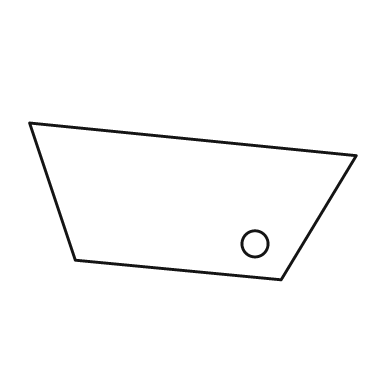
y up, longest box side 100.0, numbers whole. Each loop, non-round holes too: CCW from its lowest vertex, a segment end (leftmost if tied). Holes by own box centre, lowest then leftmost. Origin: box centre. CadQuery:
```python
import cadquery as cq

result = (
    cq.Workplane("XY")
    .moveTo(27.0, -24.0)
    .lineTo(50.0, 14.0)
    .lineTo(-50.0, 24.0)
    .lineTo(-36.0, -18.0)
    .close()
    .moveTo(19.0, -13.0)
    .circle(4.0)
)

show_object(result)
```